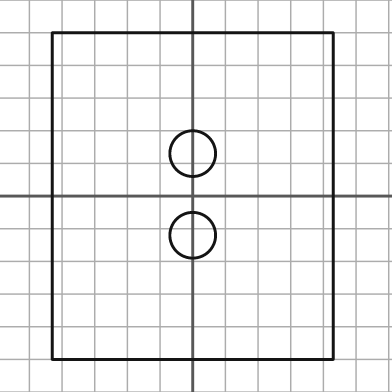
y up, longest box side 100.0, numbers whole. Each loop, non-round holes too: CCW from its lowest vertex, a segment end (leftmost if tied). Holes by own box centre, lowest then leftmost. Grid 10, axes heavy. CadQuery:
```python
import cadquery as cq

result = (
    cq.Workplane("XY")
    .moveTo(-43.0, -50.0)
    .lineTo(43.0, -50.0)
    .lineTo(43.0, 50.0)
    .lineTo(-43.0, 50.0)
    .close()
    .moveTo(0.0, -12.0)
    .circle(7.0)
    .moveTo(0.0, 13.0)
    .circle(7.0)
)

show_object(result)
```